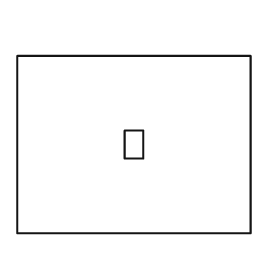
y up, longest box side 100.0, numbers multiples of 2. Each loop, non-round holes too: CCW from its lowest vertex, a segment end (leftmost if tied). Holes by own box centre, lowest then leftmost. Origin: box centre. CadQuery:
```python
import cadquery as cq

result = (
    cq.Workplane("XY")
    .moveTo(-50.0, -38.0)
    .lineTo(50.0, -38.0)
    .lineTo(50.0, 38.0)
    .lineTo(-50.0, 38.0)
    .close()
    .moveTo(-4.0, -6.0)
    .lineTo(4.0, -6.0)
    .lineTo(4.0, 6.0)
    .lineTo(-4.0, 6.0)
    .close()
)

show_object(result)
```